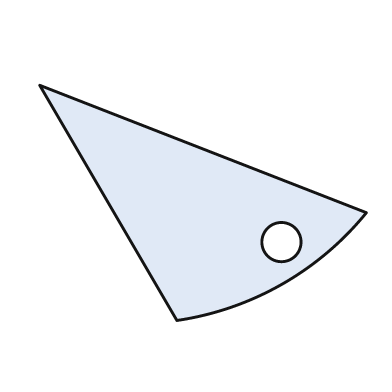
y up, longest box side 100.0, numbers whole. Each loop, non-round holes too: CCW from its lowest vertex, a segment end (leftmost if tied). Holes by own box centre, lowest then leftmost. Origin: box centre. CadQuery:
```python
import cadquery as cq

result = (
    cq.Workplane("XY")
    .moveTo(-8.0, -36.0)
    .threePointArc((24.0, -25.0), (50.0, -3.0))
    .lineTo(-50.0, 36.0)
    .close()
    .moveTo(24.0, -12.0)
    .circle(6.0)
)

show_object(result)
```